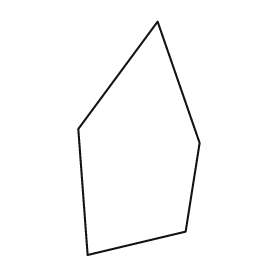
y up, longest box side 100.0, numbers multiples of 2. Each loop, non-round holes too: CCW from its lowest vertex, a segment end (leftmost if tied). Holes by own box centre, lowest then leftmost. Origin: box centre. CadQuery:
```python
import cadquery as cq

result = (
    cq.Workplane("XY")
    .moveTo(-22.0, -50.0)
    .lineTo(20.0, -40.0)
    .lineTo(26.0, -2.0)
    .lineTo(8.0, 50.0)
    .lineTo(-26.0, 4.0)
    .close()
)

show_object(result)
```